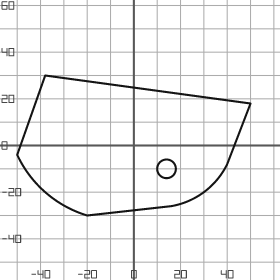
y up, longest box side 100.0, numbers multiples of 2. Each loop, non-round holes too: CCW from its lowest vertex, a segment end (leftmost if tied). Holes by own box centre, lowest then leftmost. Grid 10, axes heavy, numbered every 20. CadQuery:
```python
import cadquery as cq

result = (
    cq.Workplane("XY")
    .moveTo(-20.0, -30.0)
    .lineTo(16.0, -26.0)
    .threePointArc((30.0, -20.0), (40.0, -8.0))
    .lineTo(50.0, 18.0)
    .lineTo(-38.0, 30.0)
    .lineTo(-50.0, -4.0)
    .threePointArc((-38.0, -20.0), (-20.0, -30.0))
    .close()
    .moveTo(14.0, -10.0)
    .circle(4.0)
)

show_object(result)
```